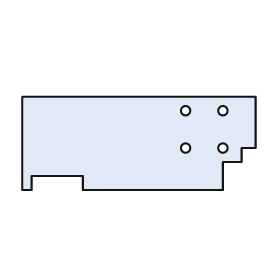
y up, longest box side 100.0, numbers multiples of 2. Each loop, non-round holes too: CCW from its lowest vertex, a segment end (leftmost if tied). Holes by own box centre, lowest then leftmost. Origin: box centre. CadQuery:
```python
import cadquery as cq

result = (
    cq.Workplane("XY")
    .moveTo(-50.0, -20.0)
    .lineTo(-46.0, -20.0)
    .lineTo(-46.0, -14.0)
    .lineTo(-24.0, -14.0)
    .lineTo(-24.0, -20.0)
    .lineTo(36.0, -20.0)
    .lineTo(36.0, -8.0)
    .lineTo(44.0, -8.0)
    .lineTo(44.0, -2.0)
    .lineTo(50.0, -2.0)
    .lineTo(50.0, 20.0)
    .lineTo(-50.0, 20.0)
    .close()
    .moveTo(20.0, -2.0)
    .circle(2.0)
    .moveTo(36.0, -2.0)
    .circle(2.0)
    .moveTo(20.0, 14.0)
    .circle(2.0)
    .moveTo(36.0, 14.0)
    .circle(2.0)
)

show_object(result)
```